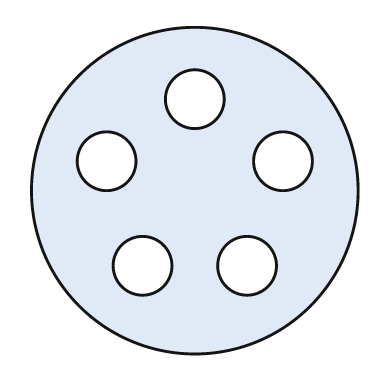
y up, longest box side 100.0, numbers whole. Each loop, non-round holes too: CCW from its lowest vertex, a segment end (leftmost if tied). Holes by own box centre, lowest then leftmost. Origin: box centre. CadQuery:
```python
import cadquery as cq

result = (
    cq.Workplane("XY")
    .moveTo(0.0, 0.0)
    .circle(50.0)
    .moveTo(-16.0, -23.0)
    .circle(9.0)
    .moveTo(16.0, -23.0)
    .circle(9.0)
    .moveTo(-27.0, 9.0)
    .circle(9.0)
    .moveTo(27.0, 9.0)
    .circle(9.0)
    .moveTo(0.0, 28.0)
    .circle(9.0)
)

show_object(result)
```